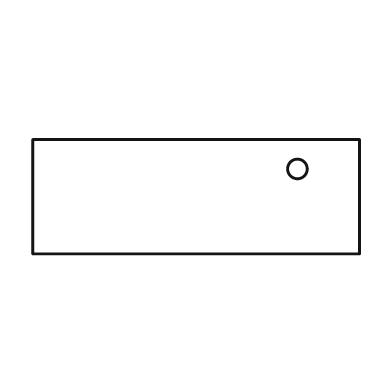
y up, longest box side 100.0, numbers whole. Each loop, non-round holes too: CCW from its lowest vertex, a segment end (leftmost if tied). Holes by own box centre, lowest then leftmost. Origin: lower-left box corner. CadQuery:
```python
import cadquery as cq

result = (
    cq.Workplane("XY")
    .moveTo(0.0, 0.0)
    .lineTo(100.0, 0.0)
    .lineTo(100.0, 35.0)
    .lineTo(0.0, 35.0)
    .close()
    .moveTo(81.0, 26.0)
    .circle(3.0)
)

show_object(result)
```